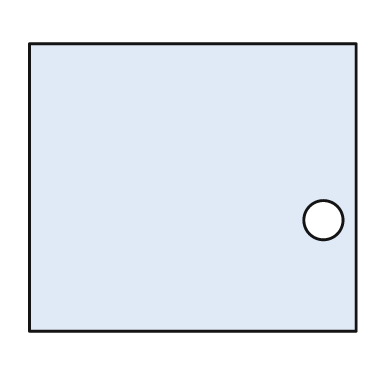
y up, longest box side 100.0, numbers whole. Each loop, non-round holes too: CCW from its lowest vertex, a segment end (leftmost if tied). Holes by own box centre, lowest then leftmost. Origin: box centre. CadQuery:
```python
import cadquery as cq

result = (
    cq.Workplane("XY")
    .moveTo(-50.0, -44.0)
    .lineTo(50.0, -44.0)
    .lineTo(50.0, 44.0)
    .lineTo(-50.0, 44.0)
    .close()
    .moveTo(40.0, -10.0)
    .circle(6.0)
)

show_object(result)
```